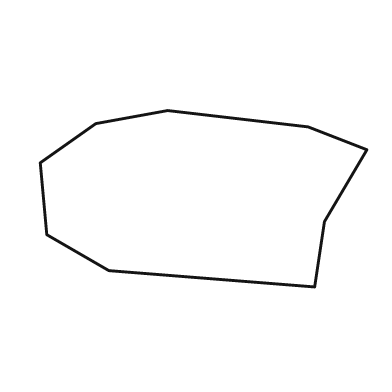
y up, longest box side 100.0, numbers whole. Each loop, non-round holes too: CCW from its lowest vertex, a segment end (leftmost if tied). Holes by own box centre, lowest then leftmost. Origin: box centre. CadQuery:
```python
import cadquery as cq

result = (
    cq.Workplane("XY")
    .moveTo(34.0, -27.0)
    .lineTo(37.0, -7.0)
    .lineTo(50.0, 15.0)
    .lineTo(32.0, 22.0)
    .lineTo(-11.0, 27.0)
    .lineTo(-33.0, 23.0)
    .lineTo(-50.0, 11.0)
    .lineTo(-48.0, -11.0)
    .lineTo(-29.0, -22.0)
    .close()
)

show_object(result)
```